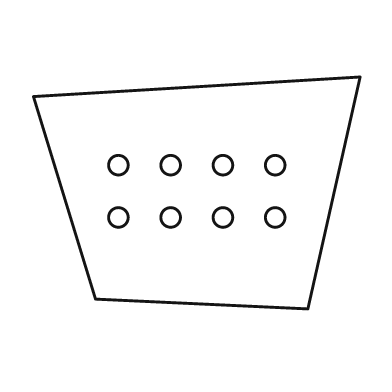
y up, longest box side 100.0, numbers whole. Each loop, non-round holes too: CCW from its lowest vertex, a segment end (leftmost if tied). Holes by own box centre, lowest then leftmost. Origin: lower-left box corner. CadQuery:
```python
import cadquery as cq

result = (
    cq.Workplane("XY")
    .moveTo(84.0, 0.0)
    .lineTo(100.0, 71.0)
    .lineTo(0.0, 65.0)
    .lineTo(19.0, 3.0)
    .close()
    .moveTo(26.0, 28.0)
    .circle(3.0)
    .moveTo(42.0, 28.0)
    .circle(3.0)
    .moveTo(58.0, 28.0)
    .circle(3.0)
    .moveTo(74.0, 28.0)
    .circle(3.0)
    .moveTo(26.0, 44.0)
    .circle(3.0)
    .moveTo(42.0, 44.0)
    .circle(3.0)
    .moveTo(58.0, 44.0)
    .circle(3.0)
    .moveTo(74.0, 44.0)
    .circle(3.0)
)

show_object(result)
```